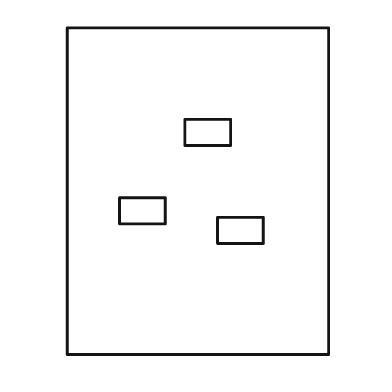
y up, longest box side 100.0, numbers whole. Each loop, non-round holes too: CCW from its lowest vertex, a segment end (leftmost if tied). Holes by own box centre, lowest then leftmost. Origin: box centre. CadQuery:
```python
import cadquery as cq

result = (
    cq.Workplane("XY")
    .moveTo(-40.0, -50.0)
    .lineTo(40.0, -50.0)
    .lineTo(40.0, 50.0)
    .lineTo(-40.0, 50.0)
    .close()
    .moveTo(6.0, -16.0)
    .lineTo(20.0, -16.0)
    .lineTo(20.0, -8.0)
    .lineTo(6.0, -8.0)
    .close()
    .moveTo(-24.0, -10.0)
    .lineTo(-10.0, -10.0)
    .lineTo(-10.0, -2.0)
    .lineTo(-24.0, -2.0)
    .close()
    .moveTo(-4.0, 14.0)
    .lineTo(10.0, 14.0)
    .lineTo(10.0, 22.0)
    .lineTo(-4.0, 22.0)
    .close()
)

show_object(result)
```